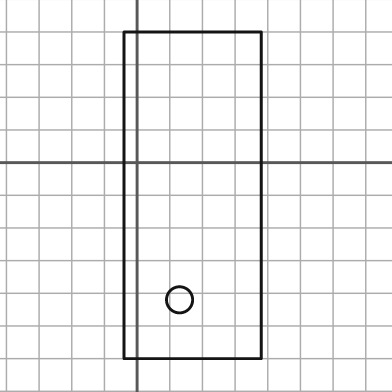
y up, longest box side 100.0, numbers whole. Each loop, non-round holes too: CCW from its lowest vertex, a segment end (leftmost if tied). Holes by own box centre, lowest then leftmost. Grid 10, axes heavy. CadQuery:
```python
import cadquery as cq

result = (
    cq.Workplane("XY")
    .moveTo(-4.0, -60.0)
    .lineTo(38.0, -60.0)
    .lineTo(38.0, 40.0)
    .lineTo(-4.0, 40.0)
    .close()
    .moveTo(13.0, -42.0)
    .circle(4.0)
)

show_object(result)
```